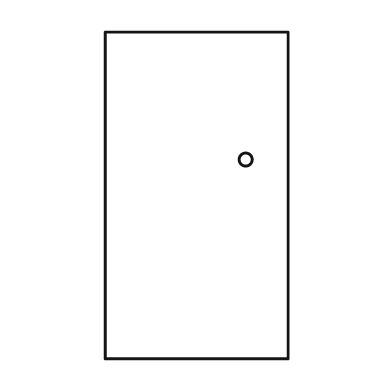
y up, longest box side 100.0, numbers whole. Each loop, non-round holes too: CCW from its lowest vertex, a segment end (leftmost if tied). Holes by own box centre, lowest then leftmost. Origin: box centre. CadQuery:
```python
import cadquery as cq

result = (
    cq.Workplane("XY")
    .moveTo(-28.0, -50.0)
    .lineTo(28.0, -50.0)
    .lineTo(28.0, 50.0)
    .lineTo(-28.0, 50.0)
    .close()
    .moveTo(15.0, 11.0)
    .circle(2.0)
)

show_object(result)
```